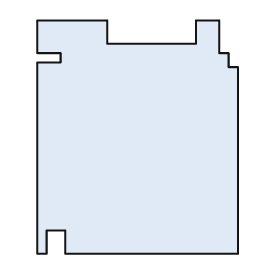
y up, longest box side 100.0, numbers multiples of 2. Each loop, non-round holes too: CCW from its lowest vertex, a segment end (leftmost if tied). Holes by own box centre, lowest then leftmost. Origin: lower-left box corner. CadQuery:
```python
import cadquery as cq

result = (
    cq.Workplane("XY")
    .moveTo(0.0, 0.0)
    .lineTo(4.0, 0.0)
    .lineTo(4.0, 10.0)
    .lineTo(12.0, 10.0)
    .lineTo(12.0, 0.0)
    .lineTo(86.0, 0.0)
    .lineTo(86.0, 80.0)
    .lineTo(82.0, 80.0)
    .lineTo(82.0, 86.0)
    .lineTo(78.0, 86.0)
    .lineTo(78.0, 100.0)
    .lineTo(68.0, 100.0)
    .lineTo(68.0, 90.0)
    .lineTo(30.0, 90.0)
    .lineTo(30.0, 100.0)
    .lineTo(0.0, 100.0)
    .lineTo(0.0, 86.0)
    .lineTo(10.0, 86.0)
    .lineTo(10.0, 82.0)
    .lineTo(0.0, 82.0)
    .close()
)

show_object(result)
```